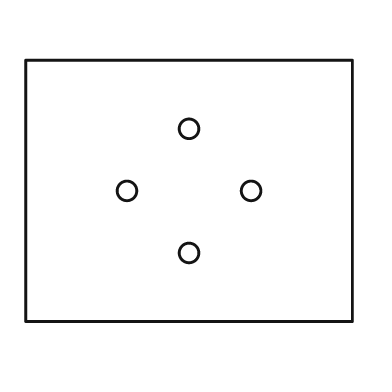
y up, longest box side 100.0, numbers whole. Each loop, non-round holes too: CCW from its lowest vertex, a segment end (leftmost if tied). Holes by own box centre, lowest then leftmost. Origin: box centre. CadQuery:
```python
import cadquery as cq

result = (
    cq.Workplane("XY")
    .moveTo(-50.0, -40.0)
    .lineTo(50.0, -40.0)
    .lineTo(50.0, 40.0)
    .lineTo(-50.0, 40.0)
    .close()
    .moveTo(0.0, -19.0)
    .circle(3.0)
    .moveTo(-19.0, 0.0)
    .circle(3.0)
    .moveTo(19.0, 0.0)
    .circle(3.0)
    .moveTo(0.0, 19.0)
    .circle(3.0)
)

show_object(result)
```